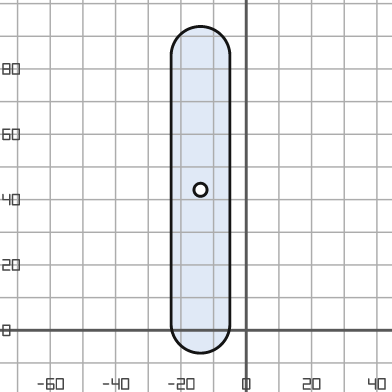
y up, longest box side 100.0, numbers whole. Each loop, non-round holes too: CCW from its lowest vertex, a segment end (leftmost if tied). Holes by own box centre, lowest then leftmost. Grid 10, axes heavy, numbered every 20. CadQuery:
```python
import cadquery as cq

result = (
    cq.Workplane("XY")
    .moveTo(-23.0, 2.0)
    .threePointArc((-14.0, -7.0), (-5.0, 2.0))
    .lineTo(-5.0, 84.0)
    .threePointArc((-14.0, 93.0), (-23.0, 84.0))
    .close()
    .moveTo(-14.0, 43.0)
    .circle(2.0)
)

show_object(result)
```